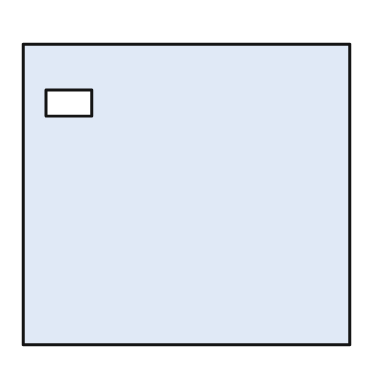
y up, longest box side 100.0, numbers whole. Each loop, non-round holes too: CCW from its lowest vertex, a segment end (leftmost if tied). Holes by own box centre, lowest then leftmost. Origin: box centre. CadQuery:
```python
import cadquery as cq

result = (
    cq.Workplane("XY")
    .moveTo(-50.0, -46.0)
    .lineTo(50.0, -46.0)
    .lineTo(50.0, 46.0)
    .lineTo(-50.0, 46.0)
    .close()
    .moveTo(-43.0, 24.0)
    .lineTo(-29.0, 24.0)
    .lineTo(-29.0, 32.0)
    .lineTo(-43.0, 32.0)
    .close()
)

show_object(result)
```